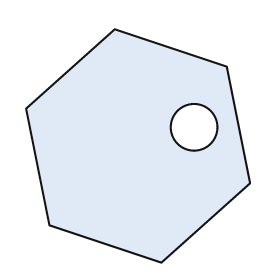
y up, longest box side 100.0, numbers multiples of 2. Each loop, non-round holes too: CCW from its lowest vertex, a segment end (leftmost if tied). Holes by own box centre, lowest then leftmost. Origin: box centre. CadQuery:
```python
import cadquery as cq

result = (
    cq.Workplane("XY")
    .moveTo(10.0, -50.0)
    .lineTo(48.0, -16.0)
    .lineTo(38.0, 34.0)
    .lineTo(-10.0, 50.0)
    .lineTo(-48.0, 16.0)
    .lineTo(-38.0, -34.0)
    .close()
    .moveTo(24.0, 8.0)
    .circle(10.0)
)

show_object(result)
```